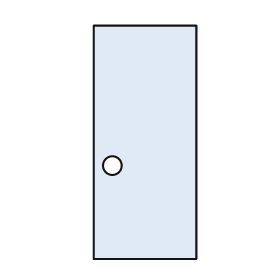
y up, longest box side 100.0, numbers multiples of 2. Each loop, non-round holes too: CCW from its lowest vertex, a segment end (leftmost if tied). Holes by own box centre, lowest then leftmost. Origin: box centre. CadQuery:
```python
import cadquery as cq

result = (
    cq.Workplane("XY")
    .moveTo(-22.0, -50.0)
    .lineTo(22.0, -50.0)
    .lineTo(22.0, 50.0)
    .lineTo(-22.0, 50.0)
    .close()
    .moveTo(-14.0, -10.0)
    .circle(4.0)
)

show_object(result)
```